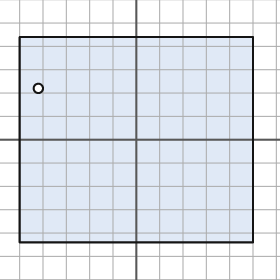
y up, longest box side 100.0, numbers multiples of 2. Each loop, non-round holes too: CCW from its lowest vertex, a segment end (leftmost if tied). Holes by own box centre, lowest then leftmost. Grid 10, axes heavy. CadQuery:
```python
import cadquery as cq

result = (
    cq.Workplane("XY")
    .moveTo(-50.0, -44.0)
    .lineTo(50.0, -44.0)
    .lineTo(50.0, 44.0)
    .lineTo(-50.0, 44.0)
    .close()
    .moveTo(-42.0, 22.0)
    .circle(2.0)
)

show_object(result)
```